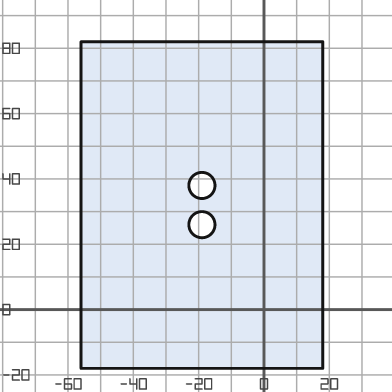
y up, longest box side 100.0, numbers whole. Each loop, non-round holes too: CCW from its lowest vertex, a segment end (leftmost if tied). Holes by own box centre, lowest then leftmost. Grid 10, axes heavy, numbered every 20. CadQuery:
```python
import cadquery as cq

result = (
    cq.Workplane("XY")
    .moveTo(-56.0, -18.0)
    .lineTo(18.0, -18.0)
    .lineTo(18.0, 82.0)
    .lineTo(-56.0, 82.0)
    .close()
    .moveTo(-19.0, 26.0)
    .circle(4.0)
    .moveTo(-19.0, 38.0)
    .circle(4.0)
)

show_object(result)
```